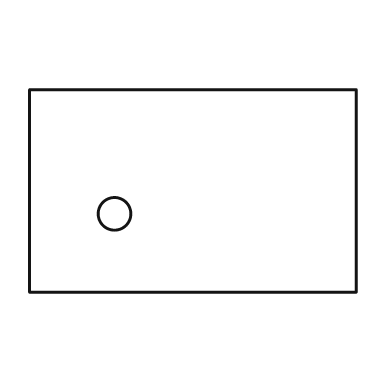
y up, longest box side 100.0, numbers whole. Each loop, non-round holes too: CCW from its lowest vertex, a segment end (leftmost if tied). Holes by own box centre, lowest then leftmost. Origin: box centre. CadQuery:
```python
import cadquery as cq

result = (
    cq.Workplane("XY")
    .moveTo(-50.0, -31.0)
    .lineTo(50.0, -31.0)
    .lineTo(50.0, 31.0)
    .lineTo(-50.0, 31.0)
    .close()
    .moveTo(-24.0, -7.0)
    .circle(5.0)
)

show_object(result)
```